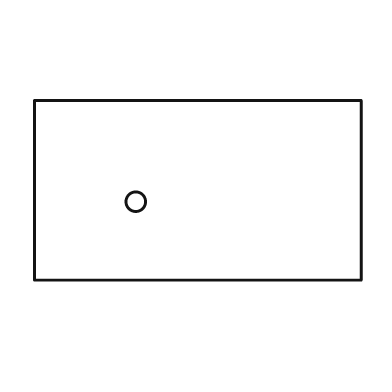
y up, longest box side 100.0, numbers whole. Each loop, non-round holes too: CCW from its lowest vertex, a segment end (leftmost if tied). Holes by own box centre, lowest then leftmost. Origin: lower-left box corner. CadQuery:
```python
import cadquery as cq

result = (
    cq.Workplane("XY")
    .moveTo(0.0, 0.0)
    .lineTo(100.0, 0.0)
    .lineTo(100.0, 55.0)
    .lineTo(0.0, 55.0)
    .close()
    .moveTo(31.0, 24.0)
    .circle(3.0)
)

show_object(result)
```